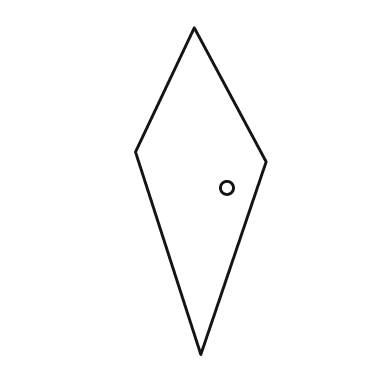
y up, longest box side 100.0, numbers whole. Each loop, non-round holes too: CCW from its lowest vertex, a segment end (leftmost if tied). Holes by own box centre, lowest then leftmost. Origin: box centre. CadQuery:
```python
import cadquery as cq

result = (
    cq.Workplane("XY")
    .moveTo(0.0, -50.0)
    .lineTo(20.0, 9.0)
    .lineTo(-2.0, 50.0)
    .lineTo(-20.0, 12.0)
    .close()
    .moveTo(8.0, 1.0)
    .circle(2.0)
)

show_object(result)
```